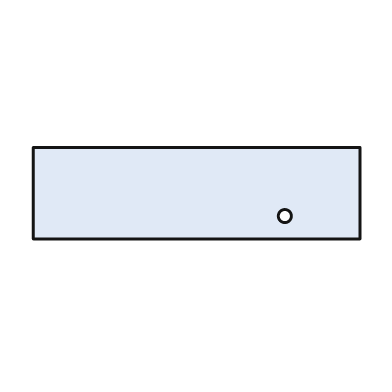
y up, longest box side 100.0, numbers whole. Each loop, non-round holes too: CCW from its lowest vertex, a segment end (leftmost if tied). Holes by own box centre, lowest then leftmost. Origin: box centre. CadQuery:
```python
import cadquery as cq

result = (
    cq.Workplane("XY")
    .moveTo(-50.0, -14.0)
    .lineTo(50.0, -14.0)
    .lineTo(50.0, 14.0)
    .lineTo(-50.0, 14.0)
    .close()
    .moveTo(27.0, -7.0)
    .circle(2.0)
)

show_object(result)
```